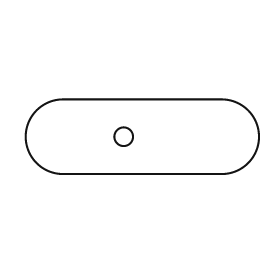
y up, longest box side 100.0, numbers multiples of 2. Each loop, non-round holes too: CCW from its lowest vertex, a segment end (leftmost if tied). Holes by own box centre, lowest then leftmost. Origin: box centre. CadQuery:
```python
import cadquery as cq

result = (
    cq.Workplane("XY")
    .moveTo(-34.0, -16.0)
    .lineTo(34.0, -16.0)
    .threePointArc((50.0, 0.0), (34.0, 16.0))
    .lineTo(-34.0, 16.0)
    .threePointArc((-50.0, 0.0), (-34.0, -16.0))
    .close()
    .moveTo(-8.0, 0.0)
    .circle(4.0)
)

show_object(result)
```